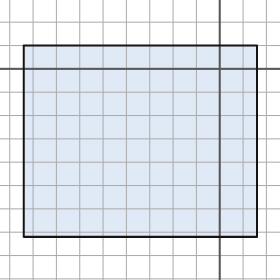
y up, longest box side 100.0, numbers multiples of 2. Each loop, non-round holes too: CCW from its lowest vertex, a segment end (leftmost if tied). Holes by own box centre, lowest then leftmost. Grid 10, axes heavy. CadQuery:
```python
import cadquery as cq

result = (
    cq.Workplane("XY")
    .moveTo(-84.0, -72.0)
    .lineTo(16.0, -72.0)
    .lineTo(16.0, 10.0)
    .lineTo(-84.0, 10.0)
    .close()
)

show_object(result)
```